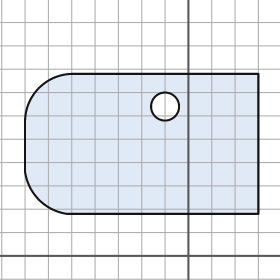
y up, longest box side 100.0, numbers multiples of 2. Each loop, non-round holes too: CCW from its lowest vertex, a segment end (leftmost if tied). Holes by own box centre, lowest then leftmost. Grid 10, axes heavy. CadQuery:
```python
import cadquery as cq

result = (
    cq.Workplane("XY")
    .moveTo(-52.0, 18.0)
    .lineTo(30.0, 18.0)
    .lineTo(30.0, 78.0)
    .lineTo(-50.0, 78.0)
    .threePointArc((-64.0, 72.0), (-70.0, 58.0))
    .lineTo(-70.0, 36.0)
    .threePointArc((-64.0, 24.0), (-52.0, 18.0))
    .close()
    .moveTo(-10.0, 64.0)
    .circle(6.0)
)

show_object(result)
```